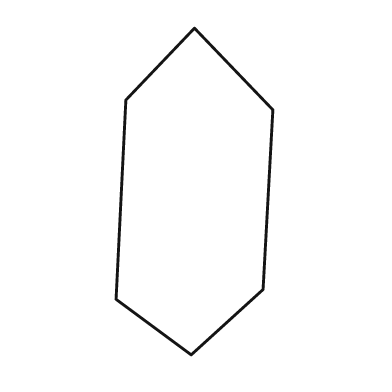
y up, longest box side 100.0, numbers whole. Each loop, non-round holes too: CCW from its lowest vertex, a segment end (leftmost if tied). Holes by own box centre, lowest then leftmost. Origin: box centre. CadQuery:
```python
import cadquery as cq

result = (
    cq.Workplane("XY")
    .moveTo(-1.0, -50.0)
    .lineTo(21.0, -30.0)
    .lineTo(24.0, 25.0)
    .lineTo(0.0, 50.0)
    .lineTo(-21.0, 28.0)
    .lineTo(-24.0, -33.0)
    .close()
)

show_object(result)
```